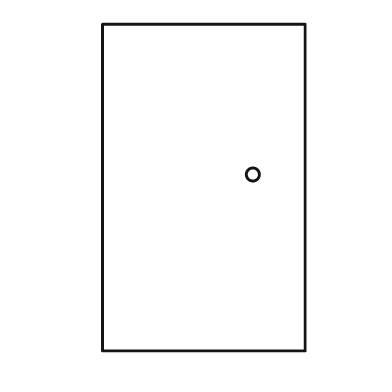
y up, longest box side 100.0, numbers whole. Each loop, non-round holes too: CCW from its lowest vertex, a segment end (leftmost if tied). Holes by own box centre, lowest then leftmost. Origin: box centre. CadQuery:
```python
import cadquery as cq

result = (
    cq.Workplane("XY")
    .moveTo(-31.0, -50.0)
    .lineTo(31.0, -50.0)
    .lineTo(31.0, 50.0)
    .lineTo(-31.0, 50.0)
    .close()
    .moveTo(15.0, 4.0)
    .circle(2.0)
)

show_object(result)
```